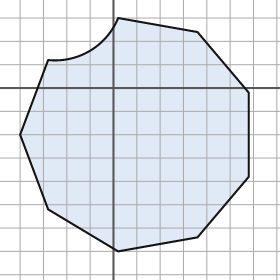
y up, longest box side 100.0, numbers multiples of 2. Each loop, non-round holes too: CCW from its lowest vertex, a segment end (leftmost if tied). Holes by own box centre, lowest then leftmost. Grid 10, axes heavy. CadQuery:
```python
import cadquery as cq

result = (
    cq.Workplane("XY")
    .moveTo(2.0, -70.0)
    .lineTo(36.0, -64.0)
    .lineTo(58.0, -38.0)
    .lineTo(58.0, -2.0)
    .lineTo(36.0, 24.0)
    .lineTo(2.0, 30.0)
    .threePointArc((-10.0, 16.0), (-28.0, 12.0))
    .lineTo(-40.0, -20.0)
    .lineTo(-28.0, -52.0)
    .close()
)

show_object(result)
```